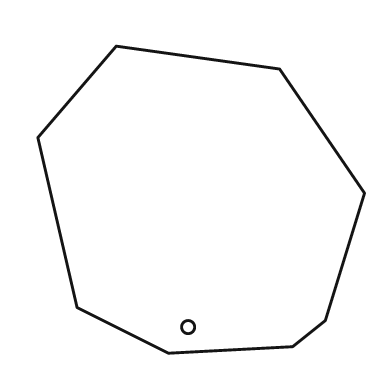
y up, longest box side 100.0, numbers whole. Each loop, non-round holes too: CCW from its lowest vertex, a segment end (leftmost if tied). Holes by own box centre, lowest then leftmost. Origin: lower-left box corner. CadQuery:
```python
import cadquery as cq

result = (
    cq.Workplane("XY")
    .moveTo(40.0, 0.0)
    .lineTo(78.0, 2.0)
    .lineTo(88.0, 10.0)
    .lineTo(100.0, 49.0)
    .lineTo(74.0, 87.0)
    .lineTo(24.0, 94.0)
    .lineTo(0.0, 66.0)
    .lineTo(12.0, 14.0)
    .close()
    .moveTo(46.0, 8.0)
    .circle(2.0)
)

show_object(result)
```